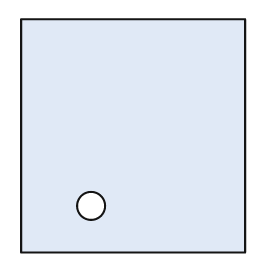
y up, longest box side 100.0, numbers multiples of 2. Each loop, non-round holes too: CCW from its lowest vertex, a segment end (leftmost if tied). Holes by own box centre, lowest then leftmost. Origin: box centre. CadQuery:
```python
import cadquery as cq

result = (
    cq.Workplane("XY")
    .moveTo(-48.0, -50.0)
    .lineTo(48.0, -50.0)
    .lineTo(48.0, 50.0)
    .lineTo(-48.0, 50.0)
    .close()
    .moveTo(-18.0, -30.0)
    .circle(6.0)
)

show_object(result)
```